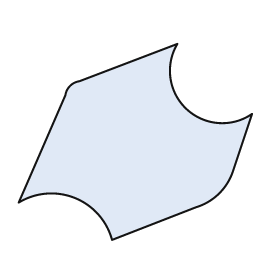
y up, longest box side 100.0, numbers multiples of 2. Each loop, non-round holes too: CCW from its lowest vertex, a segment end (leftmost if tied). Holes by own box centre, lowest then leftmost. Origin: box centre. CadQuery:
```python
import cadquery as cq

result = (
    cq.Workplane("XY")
    .moveTo(-10.0, -42.0)
    .lineTo(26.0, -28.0)
    .threePointArc((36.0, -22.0), (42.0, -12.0))
    .lineTo(50.0, 12.0)
    .threePointArc((22.0, 14.0), (18.0, 42.0))
    .lineTo(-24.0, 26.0)
    .threePointArc((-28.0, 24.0), (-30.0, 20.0))
    .lineTo(-50.0, -26.0)
    .threePointArc((-26.0, -24.0), (-10.0, -42.0))
    .close()
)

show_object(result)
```